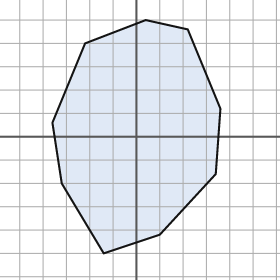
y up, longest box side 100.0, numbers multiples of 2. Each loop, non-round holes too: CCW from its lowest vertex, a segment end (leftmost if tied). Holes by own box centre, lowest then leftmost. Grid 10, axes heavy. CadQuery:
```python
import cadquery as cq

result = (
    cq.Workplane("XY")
    .moveTo(-14.0, -50.0)
    .lineTo(10.0, -42.0)
    .lineTo(34.0, -16.0)
    .lineTo(36.0, 12.0)
    .lineTo(22.0, 46.0)
    .lineTo(4.0, 50.0)
    .lineTo(-22.0, 40.0)
    .lineTo(-36.0, 6.0)
    .lineTo(-32.0, -20.0)
    .close()
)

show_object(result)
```